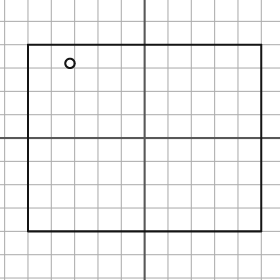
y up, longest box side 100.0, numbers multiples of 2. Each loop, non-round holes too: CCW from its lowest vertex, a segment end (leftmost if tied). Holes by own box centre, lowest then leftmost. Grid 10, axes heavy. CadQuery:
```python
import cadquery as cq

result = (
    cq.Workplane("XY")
    .moveTo(-50.0, -40.0)
    .lineTo(50.0, -40.0)
    .lineTo(50.0, 40.0)
    .lineTo(-50.0, 40.0)
    .close()
    .moveTo(-32.0, 32.0)
    .circle(2.0)
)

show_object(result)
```